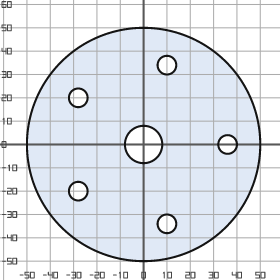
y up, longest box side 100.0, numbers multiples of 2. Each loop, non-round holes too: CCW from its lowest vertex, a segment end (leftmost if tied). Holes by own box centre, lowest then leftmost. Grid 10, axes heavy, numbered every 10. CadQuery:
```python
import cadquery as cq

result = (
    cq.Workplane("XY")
    .moveTo(0.0, 0.0)
    .circle(50.0)
    .moveTo(10.0, -34.0)
    .circle(4.0)
    .moveTo(-28.0, -20.0)
    .circle(4.0)
    .moveTo(0.0, 0.0)
    .circle(8.0)
    .moveTo(36.0, 0.0)
    .circle(4.0)
    .moveTo(-28.0, 20.0)
    .circle(4.0)
    .moveTo(10.0, 34.0)
    .circle(4.0)
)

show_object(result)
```